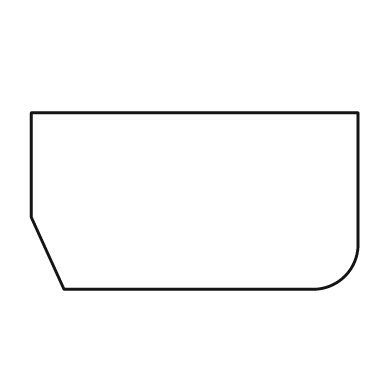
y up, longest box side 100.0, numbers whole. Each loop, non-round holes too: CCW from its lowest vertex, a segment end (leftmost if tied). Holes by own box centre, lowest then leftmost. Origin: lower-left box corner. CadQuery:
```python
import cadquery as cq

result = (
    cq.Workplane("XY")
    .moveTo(10.0, 0.0)
    .lineTo(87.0, 0.0)
    .threePointArc((96.0, 4.0), (100.0, 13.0))
    .lineTo(100.0, 54.0)
    .lineTo(0.0, 54.0)
    .lineTo(0.0, 22.0)
    .close()
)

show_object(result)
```